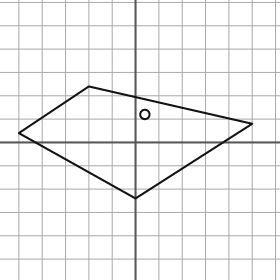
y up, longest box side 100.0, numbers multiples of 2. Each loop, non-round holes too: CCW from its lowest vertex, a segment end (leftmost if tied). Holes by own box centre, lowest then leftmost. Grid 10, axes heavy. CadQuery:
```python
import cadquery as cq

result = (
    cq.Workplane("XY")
    .moveTo(0.0, -24.0)
    .lineTo(50.0, 8.0)
    .lineTo(-20.0, 24.0)
    .lineTo(-50.0, 4.0)
    .close()
    .moveTo(4.0, 12.0)
    .circle(2.0)
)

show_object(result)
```